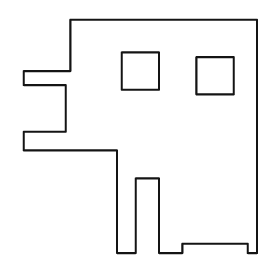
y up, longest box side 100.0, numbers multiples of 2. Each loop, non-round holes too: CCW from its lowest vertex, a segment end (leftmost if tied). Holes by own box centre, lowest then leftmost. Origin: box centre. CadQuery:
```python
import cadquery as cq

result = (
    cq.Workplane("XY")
    .moveTo(-10.0, -50.0)
    .lineTo(-2.0, -50.0)
    .lineTo(-2.0, -18.0)
    .lineTo(8.0, -18.0)
    .lineTo(8.0, -50.0)
    .lineTo(18.0, -50.0)
    .lineTo(18.0, -46.0)
    .lineTo(46.0, -46.0)
    .lineTo(46.0, -50.0)
    .lineTo(50.0, -50.0)
    .lineTo(50.0, 50.0)
    .lineTo(-30.0, 50.0)
    .lineTo(-30.0, 28.0)
    .lineTo(-50.0, 28.0)
    .lineTo(-50.0, 22.0)
    .lineTo(-32.0, 22.0)
    .lineTo(-32.0, 2.0)
    .lineTo(-50.0, 2.0)
    .lineTo(-50.0, -6.0)
    .lineTo(-10.0, -6.0)
    .close()
    .moveTo(24.0, 18.0)
    .lineTo(40.0, 18.0)
    .lineTo(40.0, 34.0)
    .lineTo(24.0, 34.0)
    .close()
    .moveTo(-8.0, 20.0)
    .lineTo(8.0, 20.0)
    .lineTo(8.0, 36.0)
    .lineTo(-8.0, 36.0)
    .close()
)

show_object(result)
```